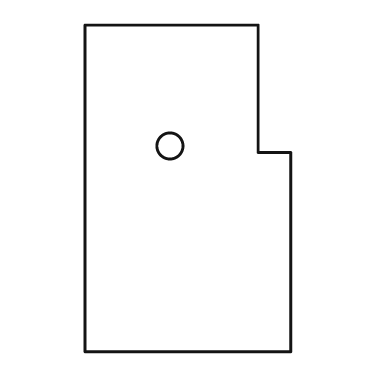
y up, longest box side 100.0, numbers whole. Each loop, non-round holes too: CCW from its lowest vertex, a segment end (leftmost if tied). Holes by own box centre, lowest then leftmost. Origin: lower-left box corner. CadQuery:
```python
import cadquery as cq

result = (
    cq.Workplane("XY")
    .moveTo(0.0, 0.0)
    .lineTo(63.0, 0.0)
    .lineTo(63.0, 61.0)
    .lineTo(53.0, 61.0)
    .lineTo(53.0, 100.0)
    .lineTo(0.0, 100.0)
    .close()
    .moveTo(26.0, 63.0)
    .circle(4.0)
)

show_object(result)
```